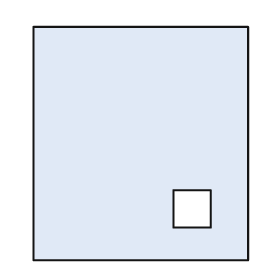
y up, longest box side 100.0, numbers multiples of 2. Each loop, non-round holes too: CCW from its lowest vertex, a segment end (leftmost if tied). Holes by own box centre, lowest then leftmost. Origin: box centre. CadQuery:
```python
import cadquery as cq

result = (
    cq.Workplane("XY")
    .moveTo(-46.0, -50.0)
    .lineTo(46.0, -50.0)
    .lineTo(46.0, 50.0)
    .lineTo(-46.0, 50.0)
    .close()
    .moveTo(14.0, -36.0)
    .lineTo(30.0, -36.0)
    .lineTo(30.0, -20.0)
    .lineTo(14.0, -20.0)
    .close()
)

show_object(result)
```